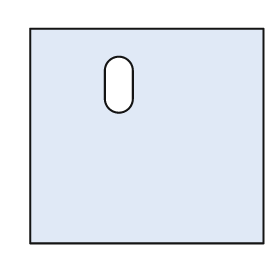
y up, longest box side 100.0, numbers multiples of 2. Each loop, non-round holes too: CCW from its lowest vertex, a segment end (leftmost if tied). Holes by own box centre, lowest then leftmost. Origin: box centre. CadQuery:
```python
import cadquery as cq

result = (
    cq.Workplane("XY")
    .moveTo(-50.0, -46.0)
    .lineTo(50.0, -46.0)
    .lineTo(50.0, 46.0)
    .lineTo(-50.0, 46.0)
    .close()
    .moveTo(-18.0, 16.0)
    .threePointArc((-12.0, 10.0), (-6.0, 16.0))
    .lineTo(-6.0, 28.0)
    .threePointArc((-12.0, 34.0), (-18.0, 28.0))
    .close()
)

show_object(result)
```